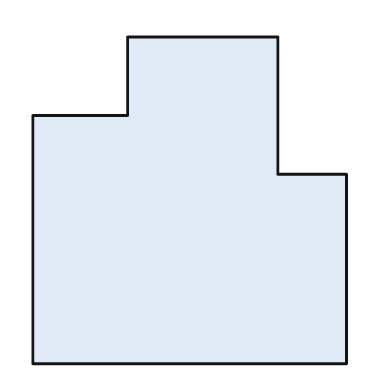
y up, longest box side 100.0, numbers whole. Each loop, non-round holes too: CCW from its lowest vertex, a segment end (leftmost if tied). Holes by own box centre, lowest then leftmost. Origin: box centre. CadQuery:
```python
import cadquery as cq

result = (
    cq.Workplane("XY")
    .moveTo(-48.0, -50.0)
    .lineTo(48.0, -50.0)
    .lineTo(48.0, 8.0)
    .lineTo(27.0, 8.0)
    .lineTo(27.0, 50.0)
    .lineTo(-19.0, 50.0)
    .lineTo(-19.0, 26.0)
    .lineTo(-48.0, 26.0)
    .close()
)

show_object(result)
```